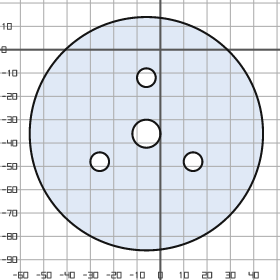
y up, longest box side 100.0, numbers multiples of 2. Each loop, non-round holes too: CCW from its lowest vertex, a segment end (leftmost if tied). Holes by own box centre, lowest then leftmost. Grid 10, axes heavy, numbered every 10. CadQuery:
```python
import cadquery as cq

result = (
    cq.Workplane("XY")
    .moveTo(-6.0, -36.0)
    .circle(50.0)
    .moveTo(-26.0, -48.0)
    .circle(4.0)
    .moveTo(14.0, -48.0)
    .circle(4.0)
    .moveTo(-6.0, -36.0)
    .circle(6.0)
    .moveTo(-6.0, -12.0)
    .circle(4.0)
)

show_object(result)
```